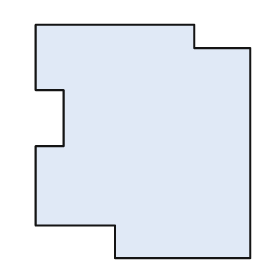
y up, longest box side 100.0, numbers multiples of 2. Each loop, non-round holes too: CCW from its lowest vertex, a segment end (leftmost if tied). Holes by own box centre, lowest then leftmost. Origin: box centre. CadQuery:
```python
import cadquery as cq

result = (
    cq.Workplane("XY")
    .moveTo(-12.0, -50.0)
    .lineTo(46.0, -50.0)
    .lineTo(46.0, 40.0)
    .lineTo(22.0, 40.0)
    .lineTo(22.0, 50.0)
    .lineTo(-46.0, 50.0)
    .lineTo(-46.0, 22.0)
    .lineTo(-34.0, 22.0)
    .lineTo(-34.0, -2.0)
    .lineTo(-46.0, -2.0)
    .lineTo(-46.0, -36.0)
    .lineTo(-12.0, -36.0)
    .close()
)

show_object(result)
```